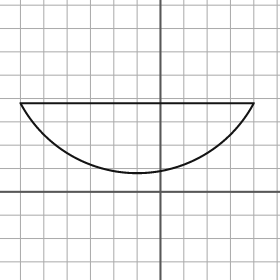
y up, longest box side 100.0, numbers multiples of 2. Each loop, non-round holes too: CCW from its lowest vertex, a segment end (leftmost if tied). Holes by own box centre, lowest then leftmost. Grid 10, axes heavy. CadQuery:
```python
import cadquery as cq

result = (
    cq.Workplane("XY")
    .moveTo(-60.0, 38.0)
    .threePointArc((-10.0, 8.0), (40.0, 38.0))
    .close()
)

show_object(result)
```